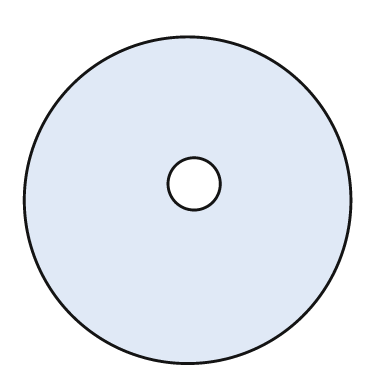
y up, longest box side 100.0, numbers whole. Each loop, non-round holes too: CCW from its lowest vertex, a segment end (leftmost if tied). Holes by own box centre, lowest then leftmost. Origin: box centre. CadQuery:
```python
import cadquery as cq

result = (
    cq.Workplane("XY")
    .moveTo(0.0, 0.0)
    .circle(50.0)
    .moveTo(2.0, 5.0)
    .circle(8.0)
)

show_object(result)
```